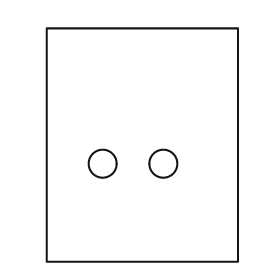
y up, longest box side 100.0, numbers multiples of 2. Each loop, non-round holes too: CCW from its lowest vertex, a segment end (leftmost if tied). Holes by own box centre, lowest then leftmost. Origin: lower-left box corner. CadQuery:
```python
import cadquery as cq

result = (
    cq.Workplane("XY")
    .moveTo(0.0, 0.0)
    .lineTo(82.0, 0.0)
    .lineTo(82.0, 100.0)
    .lineTo(0.0, 100.0)
    .close()
    .moveTo(24.0, 42.0)
    .circle(6.0)
    .moveTo(50.0, 42.0)
    .circle(6.0)
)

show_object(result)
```